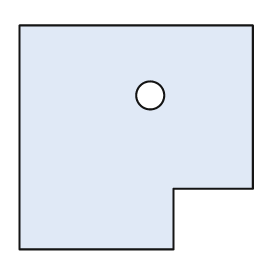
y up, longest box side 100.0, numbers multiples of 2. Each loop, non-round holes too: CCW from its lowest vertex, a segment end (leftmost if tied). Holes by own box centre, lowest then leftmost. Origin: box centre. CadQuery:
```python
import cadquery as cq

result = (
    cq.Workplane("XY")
    .moveTo(-50.0, -48.0)
    .lineTo(16.0, -48.0)
    .lineTo(16.0, -22.0)
    .lineTo(50.0, -22.0)
    .lineTo(50.0, 48.0)
    .lineTo(-50.0, 48.0)
    .close()
    .moveTo(6.0, 18.0)
    .circle(6.0)
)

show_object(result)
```